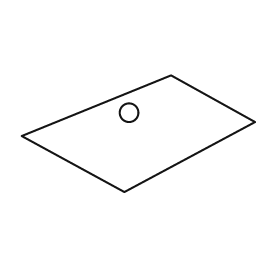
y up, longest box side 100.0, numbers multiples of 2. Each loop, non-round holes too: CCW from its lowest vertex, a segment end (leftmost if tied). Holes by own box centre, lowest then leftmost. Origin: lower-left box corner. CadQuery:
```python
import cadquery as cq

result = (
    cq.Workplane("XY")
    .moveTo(44.0, 0.0)
    .lineTo(100.0, 30.0)
    .lineTo(64.0, 50.0)
    .lineTo(0.0, 24.0)
    .close()
    .moveTo(46.0, 34.0)
    .circle(4.0)
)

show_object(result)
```